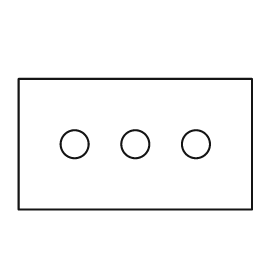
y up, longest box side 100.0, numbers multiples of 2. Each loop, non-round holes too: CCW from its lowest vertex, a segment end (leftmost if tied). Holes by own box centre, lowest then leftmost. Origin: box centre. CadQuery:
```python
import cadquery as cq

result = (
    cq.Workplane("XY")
    .moveTo(-50.0, -28.0)
    .lineTo(50.0, -28.0)
    .lineTo(50.0, 28.0)
    .lineTo(-50.0, 28.0)
    .close()
    .moveTo(-26.0, 0.0)
    .circle(6.0)
    .moveTo(0.0, 0.0)
    .circle(6.0)
    .moveTo(26.0, 0.0)
    .circle(6.0)
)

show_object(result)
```